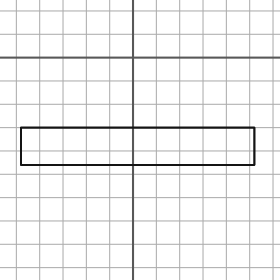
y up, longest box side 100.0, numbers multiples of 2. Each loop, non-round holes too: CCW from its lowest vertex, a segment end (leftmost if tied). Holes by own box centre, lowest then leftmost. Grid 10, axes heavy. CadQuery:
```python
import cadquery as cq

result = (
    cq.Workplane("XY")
    .moveTo(-48.0, -46.0)
    .lineTo(52.0, -46.0)
    .lineTo(52.0, -30.0)
    .lineTo(-48.0, -30.0)
    .close()
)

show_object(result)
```